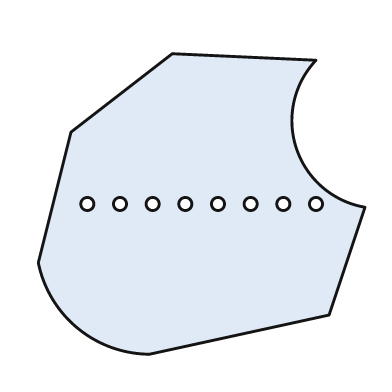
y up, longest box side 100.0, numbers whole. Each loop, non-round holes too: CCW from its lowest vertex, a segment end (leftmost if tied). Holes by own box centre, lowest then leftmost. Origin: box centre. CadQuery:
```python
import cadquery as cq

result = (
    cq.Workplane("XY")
    .moveTo(-16.0, -46.0)
    .lineTo(39.0, -34.0)
    .lineTo(50.0, -1.0)
    .threePointArc((29.0, 17.0), (35.0, 44.0))
    .lineTo(-9.0, 46.0)
    .lineTo(-40.0, 22.0)
    .lineTo(-50.0, -18.0)
    .threePointArc((-38.0, -38.0), (-16.0, -46.0))
    .close()
    .moveTo(-35.0, 0.0)
    .circle(2.0)
    .moveTo(-25.0, 0.0)
    .circle(2.0)
    .moveTo(-15.0, 0.0)
    .circle(2.0)
    .moveTo(-5.0, 0.0)
    .circle(2.0)
    .moveTo(5.0, 0.0)
    .circle(2.0)
    .moveTo(15.0, 0.0)
    .circle(2.0)
    .moveTo(25.0, 0.0)
    .circle(2.0)
    .moveTo(35.0, 0.0)
    .circle(2.0)
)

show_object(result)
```